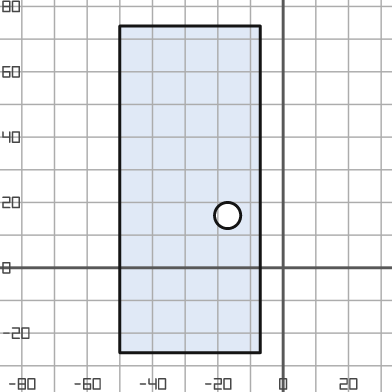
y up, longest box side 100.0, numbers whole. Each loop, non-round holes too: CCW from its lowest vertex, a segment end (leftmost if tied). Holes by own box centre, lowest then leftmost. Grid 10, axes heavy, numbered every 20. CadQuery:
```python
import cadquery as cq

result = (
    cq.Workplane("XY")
    .moveTo(-50.0, -26.0)
    .lineTo(-7.0, -26.0)
    .lineTo(-7.0, 74.0)
    .lineTo(-50.0, 74.0)
    .close()
    .moveTo(-17.0, 16.0)
    .circle(4.0)
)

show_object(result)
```